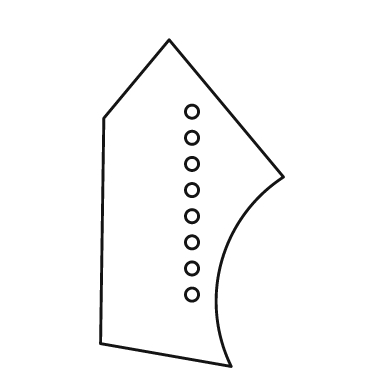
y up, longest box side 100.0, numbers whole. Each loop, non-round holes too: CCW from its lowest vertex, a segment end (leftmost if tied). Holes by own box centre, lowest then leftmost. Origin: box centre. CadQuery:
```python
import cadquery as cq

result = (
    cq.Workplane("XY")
    .moveTo(12.0, -50.0)
    .threePointArc((9.0, -18.0), (28.0, 8.0))
    .lineTo(-7.0, 50.0)
    .lineTo(-27.0, 26.0)
    .lineTo(-28.0, -43.0)
    .close()
    .moveTo(0.0, -28.0)
    .circle(2.0)
    .moveTo(0.0, -20.0)
    .circle(2.0)
    .moveTo(0.0, -12.0)
    .circle(2.0)
    .moveTo(0.0, -4.0)
    .circle(2.0)
    .moveTo(0.0, 4.0)
    .circle(2.0)
    .moveTo(0.0, 12.0)
    .circle(2.0)
    .moveTo(0.0, 20.0)
    .circle(2.0)
    .moveTo(0.0, 28.0)
    .circle(2.0)
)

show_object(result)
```